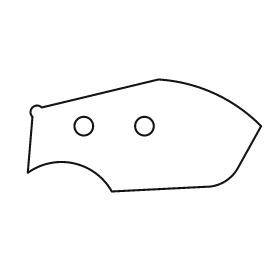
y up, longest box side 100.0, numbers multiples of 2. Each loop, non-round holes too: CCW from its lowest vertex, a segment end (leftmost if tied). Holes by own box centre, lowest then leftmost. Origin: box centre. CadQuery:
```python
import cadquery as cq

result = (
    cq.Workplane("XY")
    .moveTo(-14.0, -24.0)
    .lineTo(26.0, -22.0)
    .threePointArc((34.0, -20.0), (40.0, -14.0))
    .lineTo(50.0, 4.0)
    .threePointArc((30.0, 18.0), (6.0, 24.0))
    .lineTo(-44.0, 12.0)
    .threePointArc((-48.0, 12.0), (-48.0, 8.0))
    .lineTo(-50.0, -16.0)
    .threePointArc((-30.0, -12.0), (-14.0, -24.0))
    .close()
    .moveTo(-26.0, 4.0)
    .circle(4.0)
    .moveTo(0.0, 4.0)
    .circle(4.0)
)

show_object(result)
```